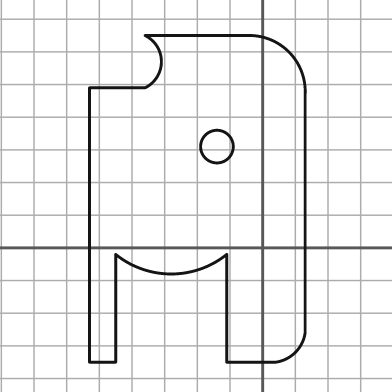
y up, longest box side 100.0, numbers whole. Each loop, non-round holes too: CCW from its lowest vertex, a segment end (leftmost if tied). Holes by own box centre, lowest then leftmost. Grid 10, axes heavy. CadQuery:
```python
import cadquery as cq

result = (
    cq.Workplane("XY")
    .moveTo(-53.0, -35.0)
    .lineTo(-45.0, -35.0)
    .lineTo(-45.0, -2.0)
    .threePointArc((-28.0, -8.0), (-11.0, -2.0))
    .lineTo(-11.0, -35.0)
    .lineTo(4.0, -35.0)
    .threePointArc((10.0, -32.0), (13.0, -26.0))
    .lineTo(13.0, 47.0)
    .threePointArc((8.0, 60.0), (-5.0, 65.0))
    .lineTo(-36.0, 65.0)
    .threePointArc((-31.0, 57.0), (-36.0, 49.0))
    .lineTo(-53.0, 49.0)
    .close()
    .moveTo(-14.0, 31.0)
    .circle(5.0)
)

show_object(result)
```